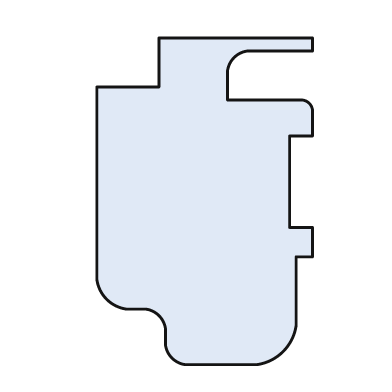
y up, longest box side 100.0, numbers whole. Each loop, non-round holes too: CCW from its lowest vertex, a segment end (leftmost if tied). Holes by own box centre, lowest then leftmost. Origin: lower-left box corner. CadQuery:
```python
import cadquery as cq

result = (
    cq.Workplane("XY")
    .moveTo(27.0, 0.0)
    .lineTo(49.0, 0.0)
    .threePointArc((57.0, 4.0), (61.0, 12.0))
    .lineTo(61.0, 33.0)
    .lineTo(66.0, 33.0)
    .lineTo(66.0, 42.0)
    .lineTo(59.0, 42.0)
    .lineTo(59.0, 70.0)
    .lineTo(66.0, 70.0)
    .lineTo(66.0, 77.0)
    .threePointArc((65.0, 80.0), (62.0, 81.0))
    .lineTo(40.0, 81.0)
    .lineTo(40.0, 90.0)
    .threePointArc((42.0, 94.0), (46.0, 96.0))
    .lineTo(66.0, 96.0)
    .lineTo(66.0, 100.0)
    .lineTo(19.0, 100.0)
    .lineTo(19.0, 85.0)
    .lineTo(0.0, 85.0)
    .lineTo(0.0, 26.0)
    .threePointArc((3.0, 20.0), (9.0, 17.0))
    .lineTo(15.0, 17.0)
    .threePointArc((19.0, 15.0), (21.0, 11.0))
    .lineTo(21.0, 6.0)
    .threePointArc((23.0, 2.0), (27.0, 0.0))
    .close()
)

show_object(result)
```